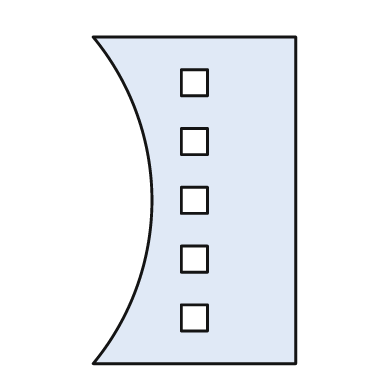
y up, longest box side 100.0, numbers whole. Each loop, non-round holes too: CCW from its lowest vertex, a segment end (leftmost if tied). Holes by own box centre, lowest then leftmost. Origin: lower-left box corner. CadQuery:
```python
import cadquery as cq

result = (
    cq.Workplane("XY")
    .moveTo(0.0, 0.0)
    .lineTo(62.0, 0.0)
    .lineTo(62.0, 100.0)
    .lineTo(0.0, 100.0)
    .threePointArc((18.0, 50.0), (0.0, 0.0))
    .close()
    .moveTo(27.0, 10.0)
    .lineTo(35.0, 10.0)
    .lineTo(35.0, 18.0)
    .lineTo(27.0, 18.0)
    .close()
    .moveTo(27.0, 28.0)
    .lineTo(35.0, 28.0)
    .lineTo(35.0, 36.0)
    .lineTo(27.0, 36.0)
    .close()
    .moveTo(27.0, 46.0)
    .lineTo(35.0, 46.0)
    .lineTo(35.0, 54.0)
    .lineTo(27.0, 54.0)
    .close()
    .moveTo(27.0, 64.0)
    .lineTo(35.0, 64.0)
    .lineTo(35.0, 72.0)
    .lineTo(27.0, 72.0)
    .close()
    .moveTo(27.0, 82.0)
    .lineTo(35.0, 82.0)
    .lineTo(35.0, 90.0)
    .lineTo(27.0, 90.0)
    .close()
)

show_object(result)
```